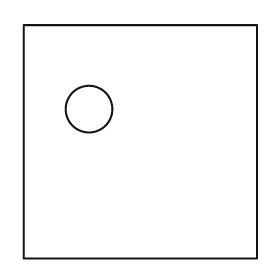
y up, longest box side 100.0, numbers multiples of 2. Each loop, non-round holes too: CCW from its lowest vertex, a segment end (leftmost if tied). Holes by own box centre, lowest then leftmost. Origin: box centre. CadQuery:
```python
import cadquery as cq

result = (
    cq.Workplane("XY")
    .moveTo(-50.0, -50.0)
    .lineTo(50.0, -50.0)
    .lineTo(50.0, 50.0)
    .lineTo(-50.0, 50.0)
    .close()
    .moveTo(-22.0, 14.0)
    .circle(10.0)
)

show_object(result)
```